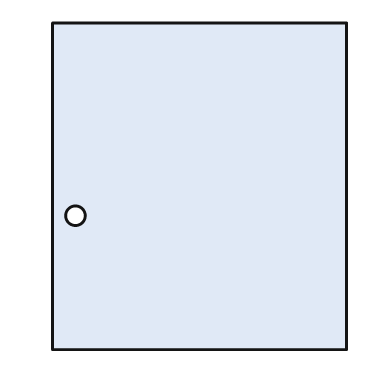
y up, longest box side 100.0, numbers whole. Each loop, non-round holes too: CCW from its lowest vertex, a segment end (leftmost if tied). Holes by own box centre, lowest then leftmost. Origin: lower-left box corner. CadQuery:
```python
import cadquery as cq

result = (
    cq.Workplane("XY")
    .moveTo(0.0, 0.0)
    .lineTo(90.0, 0.0)
    .lineTo(90.0, 100.0)
    .lineTo(0.0, 100.0)
    .close()
    .moveTo(7.0, 41.0)
    .circle(3.0)
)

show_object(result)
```